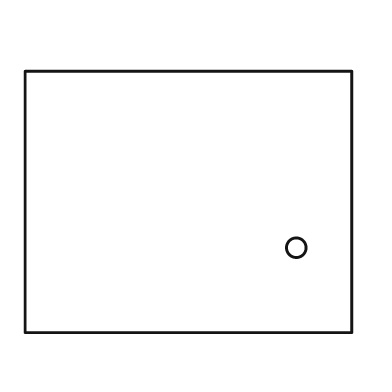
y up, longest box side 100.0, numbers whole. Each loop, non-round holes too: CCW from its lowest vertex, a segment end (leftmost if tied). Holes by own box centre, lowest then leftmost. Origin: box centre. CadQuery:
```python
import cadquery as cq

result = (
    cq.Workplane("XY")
    .moveTo(-50.0, -40.0)
    .lineTo(50.0, -40.0)
    .lineTo(50.0, 40.0)
    .lineTo(-50.0, 40.0)
    .close()
    .moveTo(33.0, -14.0)
    .circle(3.0)
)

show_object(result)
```